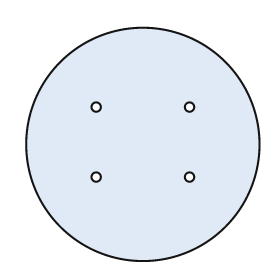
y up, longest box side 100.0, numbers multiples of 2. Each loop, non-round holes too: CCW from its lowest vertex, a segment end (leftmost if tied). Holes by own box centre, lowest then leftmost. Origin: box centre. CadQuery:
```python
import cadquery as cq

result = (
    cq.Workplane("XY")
    .moveTo(0.0, 0.0)
    .circle(50.0)
    .moveTo(-20.0, -14.0)
    .circle(2.0)
    .moveTo(20.0, -14.0)
    .circle(2.0)
    .moveTo(-20.0, 16.0)
    .circle(2.0)
    .moveTo(20.0, 16.0)
    .circle(2.0)
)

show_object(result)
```